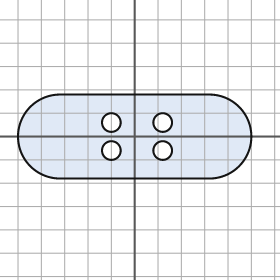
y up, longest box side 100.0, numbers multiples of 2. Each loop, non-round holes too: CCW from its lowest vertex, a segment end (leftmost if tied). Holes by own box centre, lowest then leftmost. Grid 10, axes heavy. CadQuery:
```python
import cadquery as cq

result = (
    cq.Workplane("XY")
    .moveTo(-32.0, -18.0)
    .lineTo(32.0, -18.0)
    .threePointArc((50.0, 0.0), (32.0, 18.0))
    .lineTo(-32.0, 18.0)
    .threePointArc((-50.0, 0.0), (-32.0, -18.0))
    .close()
    .moveTo(-10.0, -6.0)
    .circle(4.0)
    .moveTo(12.0, -6.0)
    .circle(4.0)
    .moveTo(-10.0, 6.0)
    .circle(4.0)
    .moveTo(12.0, 6.0)
    .circle(4.0)
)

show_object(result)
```